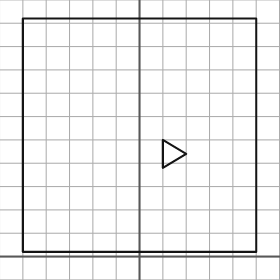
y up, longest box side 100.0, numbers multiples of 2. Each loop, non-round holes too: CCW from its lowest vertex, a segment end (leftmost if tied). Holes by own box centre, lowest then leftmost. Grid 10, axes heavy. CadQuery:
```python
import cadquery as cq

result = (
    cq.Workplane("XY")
    .moveTo(-50.0, 2.0)
    .lineTo(50.0, 2.0)
    .lineTo(50.0, 102.0)
    .lineTo(-50.0, 102.0)
    .close()
    .moveTo(10.0, 38.0)
    .lineTo(20.0, 44.0)
    .lineTo(10.0, 50.0)
    .close()
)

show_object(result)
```